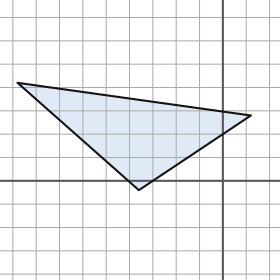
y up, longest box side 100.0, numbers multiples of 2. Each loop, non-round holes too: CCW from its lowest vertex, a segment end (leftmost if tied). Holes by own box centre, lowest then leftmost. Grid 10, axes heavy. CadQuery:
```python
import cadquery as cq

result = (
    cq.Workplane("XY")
    .moveTo(-36.0, -4.0)
    .lineTo(12.0, 28.0)
    .lineTo(-88.0, 42.0)
    .close()
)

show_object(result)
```